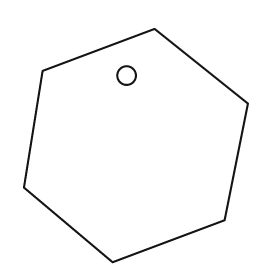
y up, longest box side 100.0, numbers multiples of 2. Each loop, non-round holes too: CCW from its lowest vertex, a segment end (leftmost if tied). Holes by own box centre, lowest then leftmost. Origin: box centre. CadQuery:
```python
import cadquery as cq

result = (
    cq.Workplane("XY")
    .moveTo(-10.0, -50.0)
    .lineTo(38.0, -32.0)
    .lineTo(48.0, 18.0)
    .lineTo(8.0, 50.0)
    .lineTo(-40.0, 32.0)
    .lineTo(-48.0, -18.0)
    .close()
    .moveTo(-4.0, 30.0)
    .circle(4.0)
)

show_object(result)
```